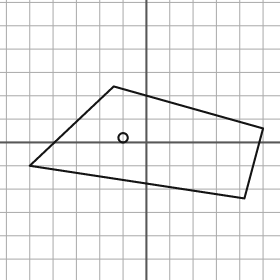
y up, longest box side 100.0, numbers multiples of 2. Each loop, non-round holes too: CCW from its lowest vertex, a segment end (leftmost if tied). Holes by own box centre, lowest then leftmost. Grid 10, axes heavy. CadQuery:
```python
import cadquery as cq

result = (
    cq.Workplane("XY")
    .moveTo(42.0, -24.0)
    .lineTo(50.0, 6.0)
    .lineTo(-14.0, 24.0)
    .lineTo(-50.0, -10.0)
    .close()
    .moveTo(-10.0, 2.0)
    .circle(2.0)
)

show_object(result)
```